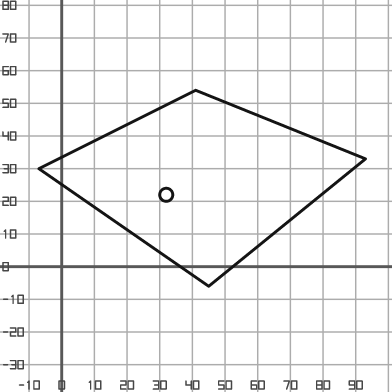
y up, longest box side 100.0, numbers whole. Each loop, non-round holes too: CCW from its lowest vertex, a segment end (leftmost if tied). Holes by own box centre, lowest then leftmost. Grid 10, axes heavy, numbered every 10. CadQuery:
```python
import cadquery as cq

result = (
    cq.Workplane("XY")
    .moveTo(45.0, -6.0)
    .lineTo(93.0, 33.0)
    .lineTo(41.0, 54.0)
    .lineTo(-7.0, 30.0)
    .close()
    .moveTo(32.0, 22.0)
    .circle(2.0)
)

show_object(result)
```